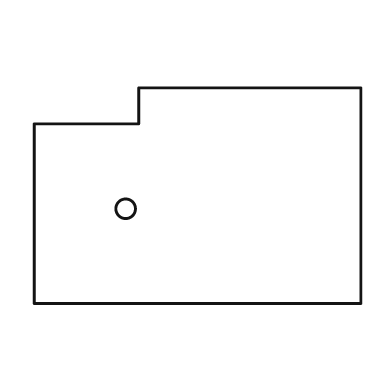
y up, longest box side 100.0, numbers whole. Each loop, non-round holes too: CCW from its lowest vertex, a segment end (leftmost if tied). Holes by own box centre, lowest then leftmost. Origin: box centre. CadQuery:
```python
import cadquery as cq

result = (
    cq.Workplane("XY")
    .moveTo(-50.0, -33.0)
    .lineTo(50.0, -33.0)
    .lineTo(50.0, 33.0)
    .lineTo(-18.0, 33.0)
    .lineTo(-18.0, 22.0)
    .lineTo(-50.0, 22.0)
    .close()
    .moveTo(-22.0, -4.0)
    .circle(3.0)
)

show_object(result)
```